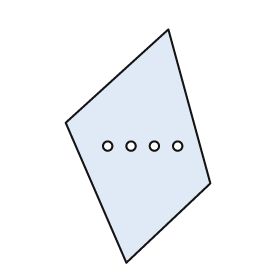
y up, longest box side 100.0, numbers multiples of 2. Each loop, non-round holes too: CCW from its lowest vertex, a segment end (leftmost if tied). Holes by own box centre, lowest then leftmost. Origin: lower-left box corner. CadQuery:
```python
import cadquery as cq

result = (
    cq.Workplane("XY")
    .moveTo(26.0, 0.0)
    .lineTo(62.0, 34.0)
    .lineTo(44.0, 100.0)
    .lineTo(0.0, 60.0)
    .close()
    .moveTo(18.0, 50.0)
    .circle(2.0)
    .moveTo(28.0, 50.0)
    .circle(2.0)
    .moveTo(38.0, 50.0)
    .circle(2.0)
    .moveTo(48.0, 50.0)
    .circle(2.0)
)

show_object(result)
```